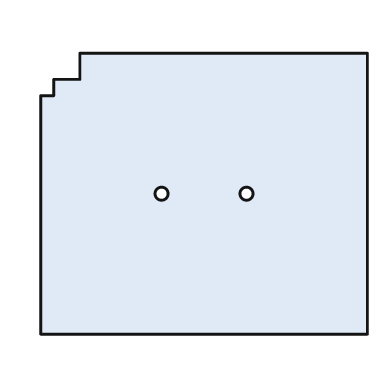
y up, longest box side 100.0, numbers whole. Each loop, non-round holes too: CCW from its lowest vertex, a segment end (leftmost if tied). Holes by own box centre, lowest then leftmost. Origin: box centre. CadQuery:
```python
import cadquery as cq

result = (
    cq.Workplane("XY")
    .moveTo(-50.0, -43.0)
    .lineTo(50.0, -43.0)
    .lineTo(50.0, 43.0)
    .lineTo(-38.0, 43.0)
    .lineTo(-38.0, 35.0)
    .lineTo(-46.0, 35.0)
    .lineTo(-46.0, 30.0)
    .lineTo(-50.0, 30.0)
    .close()
    .moveTo(-13.0, 0.0)
    .circle(2.0)
    .moveTo(13.0, 0.0)
    .circle(2.0)
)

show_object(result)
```